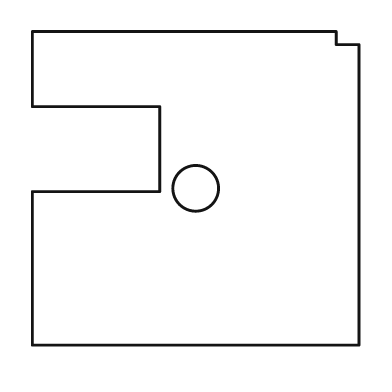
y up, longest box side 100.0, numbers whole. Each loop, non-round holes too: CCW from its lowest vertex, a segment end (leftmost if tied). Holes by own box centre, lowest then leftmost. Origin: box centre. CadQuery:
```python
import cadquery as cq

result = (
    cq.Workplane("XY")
    .moveTo(-50.0, -48.0)
    .lineTo(50.0, -48.0)
    .lineTo(50.0, 44.0)
    .lineTo(43.0, 44.0)
    .lineTo(43.0, 48.0)
    .lineTo(-50.0, 48.0)
    .lineTo(-50.0, 25.0)
    .lineTo(-11.0, 25.0)
    .lineTo(-11.0, -1.0)
    .lineTo(-50.0, -1.0)
    .close()
    .moveTo(0.0, 0.0)
    .circle(7.0)
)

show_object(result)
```